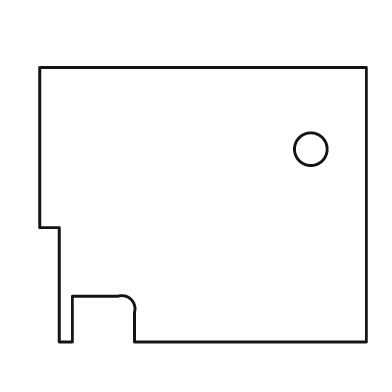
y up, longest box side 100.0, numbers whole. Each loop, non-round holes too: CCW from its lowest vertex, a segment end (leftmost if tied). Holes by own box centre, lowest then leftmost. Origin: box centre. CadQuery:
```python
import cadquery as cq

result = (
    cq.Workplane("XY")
    .moveTo(-44.0, -42.0)
    .lineTo(-40.0, -42.0)
    .lineTo(-40.0, -28.0)
    .lineTo(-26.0, -28.0)
    .threePointArc((-22.0, -29.0), (-21.0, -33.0))
    .lineTo(-21.0, -42.0)
    .lineTo(50.0, -42.0)
    .lineTo(50.0, 42.0)
    .lineTo(-50.0, 42.0)
    .lineTo(-50.0, -7.0)
    .lineTo(-44.0, -7.0)
    .close()
    .moveTo(33.0, 17.0)
    .circle(5.0)
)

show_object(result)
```